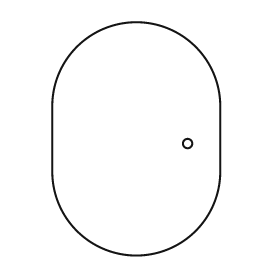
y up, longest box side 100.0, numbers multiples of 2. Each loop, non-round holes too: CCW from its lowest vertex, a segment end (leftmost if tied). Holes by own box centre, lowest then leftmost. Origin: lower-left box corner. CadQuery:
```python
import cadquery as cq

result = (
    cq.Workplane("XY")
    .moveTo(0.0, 36.0)
    .threePointArc((36.0, 0.0), (72.0, 36.0))
    .lineTo(72.0, 64.0)
    .threePointArc((36.0, 100.0), (0.0, 64.0))
    .close()
    .moveTo(58.0, 48.0)
    .circle(2.0)
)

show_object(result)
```